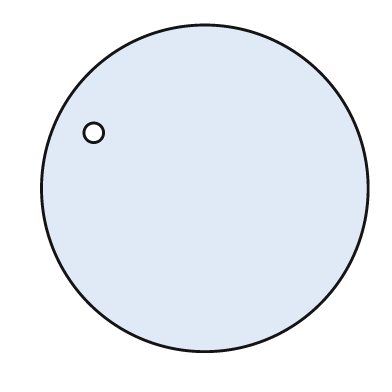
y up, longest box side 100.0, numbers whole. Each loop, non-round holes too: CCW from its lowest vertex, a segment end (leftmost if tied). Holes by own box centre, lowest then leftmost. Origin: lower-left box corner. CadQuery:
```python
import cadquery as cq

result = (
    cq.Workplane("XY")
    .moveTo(50.0, 50.0)
    .circle(50.0)
    .moveTo(16.0, 67.0)
    .circle(3.0)
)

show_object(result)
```